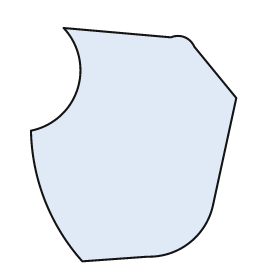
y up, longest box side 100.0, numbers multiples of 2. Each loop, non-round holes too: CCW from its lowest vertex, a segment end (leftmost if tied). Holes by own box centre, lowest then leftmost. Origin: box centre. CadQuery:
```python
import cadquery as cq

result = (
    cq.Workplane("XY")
    .moveTo(-22.0, -50.0)
    .lineTo(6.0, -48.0)
    .threePointArc((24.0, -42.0), (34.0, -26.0))
    .lineTo(44.0, 20.0)
    .lineTo(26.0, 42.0)
    .threePointArc((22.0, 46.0), (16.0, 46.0))
    .lineTo(-30.0, 50.0)
    .threePointArc((-24.0, 24.0), (-44.0, 6.0))
    .threePointArc((-38.0, -24.0), (-22.0, -50.0))
    .close()
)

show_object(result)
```